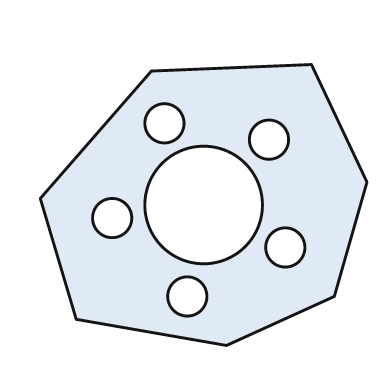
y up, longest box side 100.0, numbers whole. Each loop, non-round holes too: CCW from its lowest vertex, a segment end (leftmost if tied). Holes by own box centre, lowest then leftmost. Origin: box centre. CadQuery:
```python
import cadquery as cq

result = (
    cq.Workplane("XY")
    .moveTo(7.0, -43.0)
    .lineTo(40.0, -28.0)
    .lineTo(50.0, 7.0)
    .lineTo(33.0, 43.0)
    .lineTo(-16.0, 41.0)
    .lineTo(-50.0, 2.0)
    .lineTo(-39.0, -35.0)
    .close()
    .moveTo(-5.0, -28.0)
    .circle(6.0)
    .moveTo(25.0, -13.0)
    .circle(6.0)
    .moveTo(-28.0, -4.0)
    .circle(6.0)
    .moveTo(0.0, 0.0)
    .circle(18.0)
    .moveTo(20.0, 20.0)
    .circle(6.0)
    .moveTo(-12.0, 25.0)
    .circle(6.0)
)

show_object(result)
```